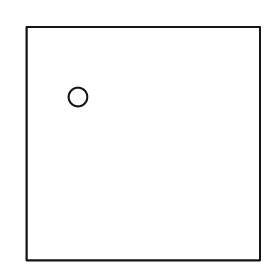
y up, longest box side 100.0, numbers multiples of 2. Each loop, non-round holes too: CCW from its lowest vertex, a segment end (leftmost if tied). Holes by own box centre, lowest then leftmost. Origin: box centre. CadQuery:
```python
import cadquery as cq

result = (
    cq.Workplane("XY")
    .moveTo(-50.0, -50.0)
    .lineTo(50.0, -50.0)
    .lineTo(50.0, 50.0)
    .lineTo(-50.0, 50.0)
    .close()
    .moveTo(-28.0, 20.0)
    .circle(4.0)
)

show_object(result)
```